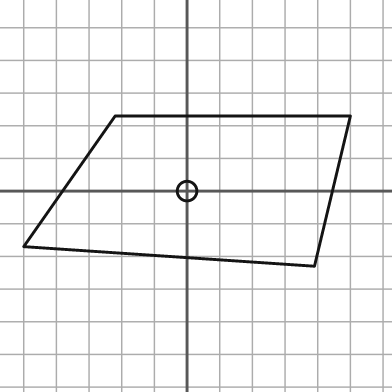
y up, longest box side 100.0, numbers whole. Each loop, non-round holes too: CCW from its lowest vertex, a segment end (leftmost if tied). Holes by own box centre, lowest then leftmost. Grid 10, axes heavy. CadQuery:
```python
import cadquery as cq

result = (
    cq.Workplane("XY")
    .moveTo(39.0, -23.0)
    .lineTo(50.0, 23.0)
    .lineTo(-22.0, 23.0)
    .lineTo(-50.0, -17.0)
    .close()
    .moveTo(0.0, 0.0)
    .circle(3.0)
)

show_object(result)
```